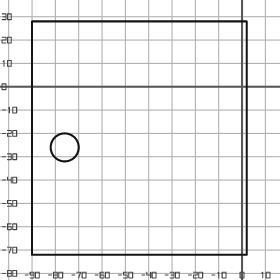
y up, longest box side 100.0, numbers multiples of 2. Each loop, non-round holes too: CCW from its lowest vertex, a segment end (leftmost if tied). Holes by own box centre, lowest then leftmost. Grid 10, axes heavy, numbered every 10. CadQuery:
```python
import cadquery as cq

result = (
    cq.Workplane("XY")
    .moveTo(-90.0, -72.0)
    .lineTo(2.0, -72.0)
    .lineTo(2.0, 28.0)
    .lineTo(-90.0, 28.0)
    .close()
    .moveTo(-76.0, -26.0)
    .circle(6.0)
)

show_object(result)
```